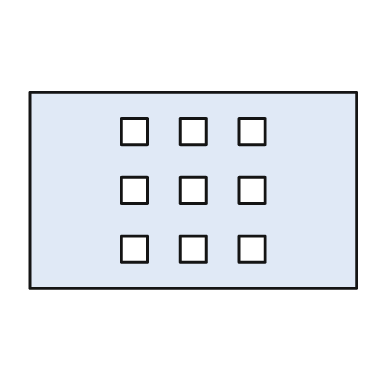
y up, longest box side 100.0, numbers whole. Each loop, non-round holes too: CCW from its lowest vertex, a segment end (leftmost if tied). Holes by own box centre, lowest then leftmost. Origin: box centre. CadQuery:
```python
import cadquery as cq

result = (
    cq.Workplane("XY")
    .moveTo(-50.0, -30.0)
    .lineTo(50.0, -30.0)
    .lineTo(50.0, 30.0)
    .lineTo(-50.0, 30.0)
    .close()
    .moveTo(-22.0, -22.0)
    .lineTo(-14.0, -22.0)
    .lineTo(-14.0, -14.0)
    .lineTo(-22.0, -14.0)
    .close()
    .moveTo(-4.0, -22.0)
    .lineTo(4.0, -22.0)
    .lineTo(4.0, -14.0)
    .lineTo(-4.0, -14.0)
    .close()
    .moveTo(14.0, -22.0)
    .lineTo(22.0, -22.0)
    .lineTo(22.0, -14.0)
    .lineTo(14.0, -14.0)
    .close()
    .moveTo(-22.0, -4.0)
    .lineTo(-14.0, -4.0)
    .lineTo(-14.0, 4.0)
    .lineTo(-22.0, 4.0)
    .close()
    .moveTo(-4.0, -4.0)
    .lineTo(4.0, -4.0)
    .lineTo(4.0, 4.0)
    .lineTo(-4.0, 4.0)
    .close()
    .moveTo(14.0, -4.0)
    .lineTo(22.0, -4.0)
    .lineTo(22.0, 4.0)
    .lineTo(14.0, 4.0)
    .close()
    .moveTo(-22.0, 14.0)
    .lineTo(-14.0, 14.0)
    .lineTo(-14.0, 22.0)
    .lineTo(-22.0, 22.0)
    .close()
    .moveTo(-4.0, 14.0)
    .lineTo(4.0, 14.0)
    .lineTo(4.0, 22.0)
    .lineTo(-4.0, 22.0)
    .close()
    .moveTo(14.0, 14.0)
    .lineTo(22.0, 14.0)
    .lineTo(22.0, 22.0)
    .lineTo(14.0, 22.0)
    .close()
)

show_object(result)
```